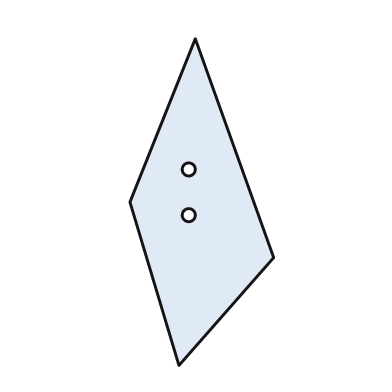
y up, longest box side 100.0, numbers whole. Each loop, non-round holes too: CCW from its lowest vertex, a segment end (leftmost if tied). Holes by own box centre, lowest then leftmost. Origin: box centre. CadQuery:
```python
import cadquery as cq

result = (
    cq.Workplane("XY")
    .moveTo(-7.0, -50.0)
    .lineTo(22.0, -17.0)
    .lineTo(-2.0, 50.0)
    .lineTo(-22.0, 0.0)
    .close()
    .moveTo(-4.0, -4.0)
    .circle(2.0)
    .moveTo(-4.0, 10.0)
    .circle(2.0)
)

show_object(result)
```